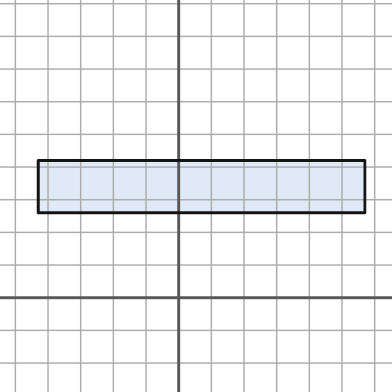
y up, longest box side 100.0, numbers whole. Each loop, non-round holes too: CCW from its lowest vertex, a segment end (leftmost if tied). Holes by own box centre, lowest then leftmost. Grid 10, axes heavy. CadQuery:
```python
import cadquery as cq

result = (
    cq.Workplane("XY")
    .moveTo(-43.0, 26.0)
    .lineTo(57.0, 26.0)
    .lineTo(57.0, 42.0)
    .lineTo(-43.0, 42.0)
    .close()
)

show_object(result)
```